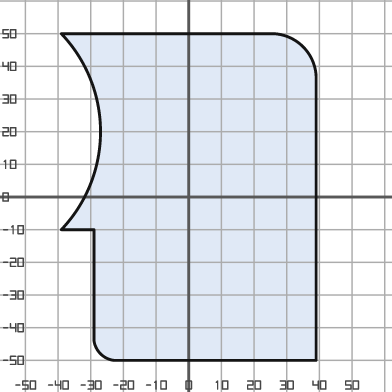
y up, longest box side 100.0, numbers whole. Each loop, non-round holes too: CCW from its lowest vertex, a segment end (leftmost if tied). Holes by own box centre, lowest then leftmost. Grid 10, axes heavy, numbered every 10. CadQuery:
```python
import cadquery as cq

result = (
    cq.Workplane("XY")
    .moveTo(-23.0, -50.0)
    .lineTo(39.0, -50.0)
    .lineTo(39.0, 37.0)
    .threePointArc((35.0, 46.0), (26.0, 50.0))
    .lineTo(-39.0, 50.0)
    .threePointArc((-27.0, 20.0), (-39.0, -10.0))
    .lineTo(-29.0, -10.0)
    .lineTo(-29.0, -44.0)
    .threePointArc((-27.0, -48.0), (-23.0, -50.0))
    .close()
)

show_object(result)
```